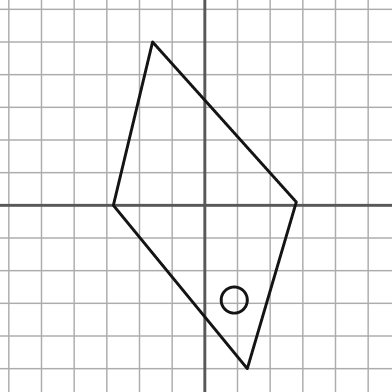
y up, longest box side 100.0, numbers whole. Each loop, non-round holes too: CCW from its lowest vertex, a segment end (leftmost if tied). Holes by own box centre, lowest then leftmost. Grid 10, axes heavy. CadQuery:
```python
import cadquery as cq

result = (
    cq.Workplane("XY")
    .moveTo(13.0, -50.0)
    .lineTo(28.0, 1.0)
    .lineTo(-16.0, 50.0)
    .lineTo(-28.0, 0.0)
    .close()
    .moveTo(9.0, -29.0)
    .circle(4.0)
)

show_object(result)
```